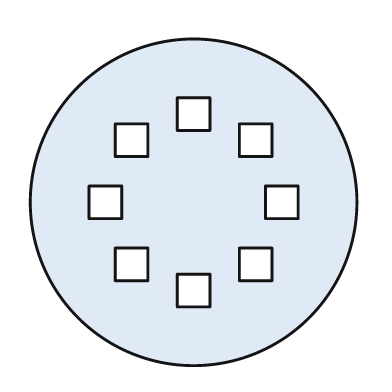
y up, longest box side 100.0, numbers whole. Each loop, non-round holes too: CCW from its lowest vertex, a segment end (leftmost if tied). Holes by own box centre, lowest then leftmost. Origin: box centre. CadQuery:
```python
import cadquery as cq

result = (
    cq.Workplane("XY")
    .moveTo(0.0, 0.0)
    .circle(50.0)
    .moveTo(-5.0, -32.0)
    .lineTo(5.0, -32.0)
    .lineTo(5.0, -22.0)
    .lineTo(-5.0, -22.0)
    .close()
    .moveTo(-24.0, -24.0)
    .lineTo(-14.0, -24.0)
    .lineTo(-14.0, -14.0)
    .lineTo(-24.0, -14.0)
    .close()
    .moveTo(14.0, -24.0)
    .lineTo(24.0, -24.0)
    .lineTo(24.0, -14.0)
    .lineTo(14.0, -14.0)
    .close()
    .moveTo(-32.0, -5.0)
    .lineTo(-22.0, -5.0)
    .lineTo(-22.0, 5.0)
    .lineTo(-32.0, 5.0)
    .close()
    .moveTo(22.0, -5.0)
    .lineTo(32.0, -5.0)
    .lineTo(32.0, 5.0)
    .lineTo(22.0, 5.0)
    .close()
    .moveTo(-24.0, 14.0)
    .lineTo(-14.0, 14.0)
    .lineTo(-14.0, 24.0)
    .lineTo(-24.0, 24.0)
    .close()
    .moveTo(14.0, 14.0)
    .lineTo(24.0, 14.0)
    .lineTo(24.0, 24.0)
    .lineTo(14.0, 24.0)
    .close()
    .moveTo(-5.0, 22.0)
    .lineTo(5.0, 22.0)
    .lineTo(5.0, 32.0)
    .lineTo(-5.0, 32.0)
    .close()
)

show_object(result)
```